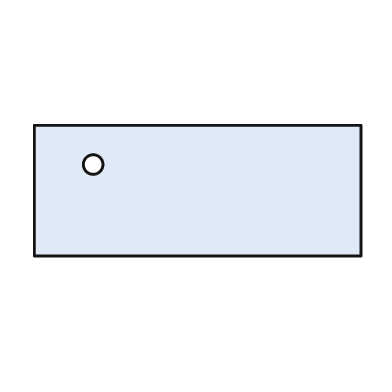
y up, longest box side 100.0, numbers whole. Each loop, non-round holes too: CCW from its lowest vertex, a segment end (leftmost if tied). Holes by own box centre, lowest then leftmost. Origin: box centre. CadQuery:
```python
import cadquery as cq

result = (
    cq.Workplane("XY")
    .moveTo(-50.0, -20.0)
    .lineTo(50.0, -20.0)
    .lineTo(50.0, 20.0)
    .lineTo(-50.0, 20.0)
    .close()
    .moveTo(-32.0, 8.0)
    .circle(3.0)
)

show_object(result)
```